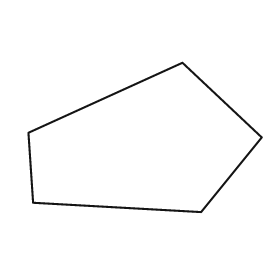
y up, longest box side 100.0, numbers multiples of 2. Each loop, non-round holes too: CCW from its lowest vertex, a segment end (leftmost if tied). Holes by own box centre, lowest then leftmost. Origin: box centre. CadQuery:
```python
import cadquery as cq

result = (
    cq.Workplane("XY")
    .moveTo(24.0, -32.0)
    .lineTo(50.0, 0.0)
    .lineTo(16.0, 32.0)
    .lineTo(-50.0, 2.0)
    .lineTo(-48.0, -28.0)
    .close()
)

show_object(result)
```